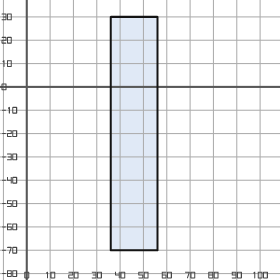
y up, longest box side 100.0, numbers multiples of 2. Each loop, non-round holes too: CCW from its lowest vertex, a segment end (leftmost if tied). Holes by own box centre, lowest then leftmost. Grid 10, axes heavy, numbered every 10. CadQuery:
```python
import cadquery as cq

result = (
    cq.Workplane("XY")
    .moveTo(36.0, -70.0)
    .lineTo(56.0, -70.0)
    .lineTo(56.0, 30.0)
    .lineTo(36.0, 30.0)
    .close()
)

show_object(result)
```